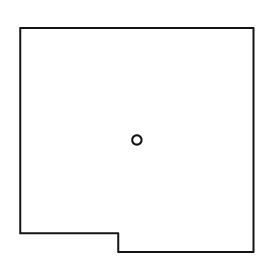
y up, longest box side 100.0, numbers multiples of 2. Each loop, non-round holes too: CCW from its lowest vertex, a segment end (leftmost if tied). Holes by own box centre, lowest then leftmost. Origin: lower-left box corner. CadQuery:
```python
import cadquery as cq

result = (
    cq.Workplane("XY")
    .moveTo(42.0, 0.0)
    .lineTo(100.0, 0.0)
    .lineTo(100.0, 96.0)
    .lineTo(0.0, 96.0)
    .lineTo(0.0, 8.0)
    .lineTo(42.0, 8.0)
    .close()
    .moveTo(50.0, 48.0)
    .circle(2.0)
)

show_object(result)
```